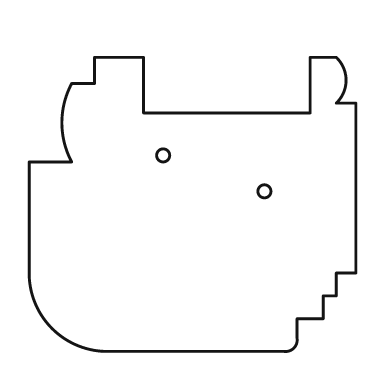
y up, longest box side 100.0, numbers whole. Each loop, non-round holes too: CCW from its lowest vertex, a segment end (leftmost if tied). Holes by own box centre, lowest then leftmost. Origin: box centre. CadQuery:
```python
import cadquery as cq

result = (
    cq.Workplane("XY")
    .moveTo(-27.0, -45.0)
    .lineTo(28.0, -45.0)
    .threePointArc((31.0, -44.0), (32.0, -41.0))
    .lineTo(32.0, -35.0)
    .lineTo(40.0, -35.0)
    .lineTo(40.0, -28.0)
    .lineTo(44.0, -28.0)
    .lineTo(44.0, -21.0)
    .lineTo(50.0, -21.0)
    .lineTo(50.0, 31.0)
    .lineTo(44.0, 31.0)
    .threePointArc((47.0, 38.0), (44.0, 45.0))
    .lineTo(36.0, 45.0)
    .lineTo(36.0, 28.0)
    .lineTo(-15.0, 28.0)
    .lineTo(-15.0, 45.0)
    .lineTo(-30.0, 45.0)
    .lineTo(-30.0, 37.0)
    .lineTo(-37.0, 37.0)
    .threePointArc((-40.0, 25.0), (-37.0, 13.0))
    .lineTo(-50.0, 13.0)
    .lineTo(-50.0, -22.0)
    .threePointArc((-43.0, -38.0), (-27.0, -45.0))
    .close()
    .moveTo(22.0, 4.0)
    .circle(2.0)
    .moveTo(-9.0, 15.0)
    .circle(2.0)
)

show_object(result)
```